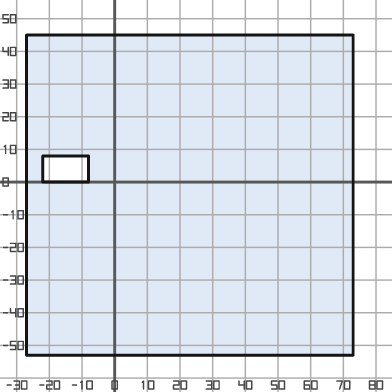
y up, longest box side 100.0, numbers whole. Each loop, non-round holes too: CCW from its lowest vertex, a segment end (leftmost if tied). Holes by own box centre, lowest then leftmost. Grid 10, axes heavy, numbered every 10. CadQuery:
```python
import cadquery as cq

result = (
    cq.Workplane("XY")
    .moveTo(-27.0, -53.0)
    .lineTo(73.0, -53.0)
    .lineTo(73.0, 45.0)
    .lineTo(-27.0, 45.0)
    .close()
    .moveTo(-22.0, 0.0)
    .lineTo(-8.0, 0.0)
    .lineTo(-8.0, 8.0)
    .lineTo(-22.0, 8.0)
    .close()
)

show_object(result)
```